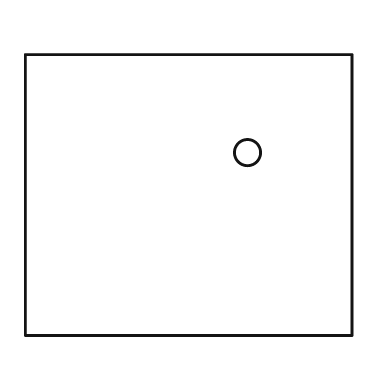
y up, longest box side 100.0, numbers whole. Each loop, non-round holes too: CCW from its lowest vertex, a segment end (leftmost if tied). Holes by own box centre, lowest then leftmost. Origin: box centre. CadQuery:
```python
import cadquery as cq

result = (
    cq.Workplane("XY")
    .moveTo(-50.0, -43.0)
    .lineTo(50.0, -43.0)
    .lineTo(50.0, 43.0)
    .lineTo(-50.0, 43.0)
    .close()
    .moveTo(18.0, 13.0)
    .circle(4.0)
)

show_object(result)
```